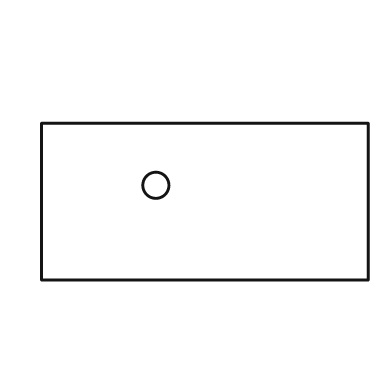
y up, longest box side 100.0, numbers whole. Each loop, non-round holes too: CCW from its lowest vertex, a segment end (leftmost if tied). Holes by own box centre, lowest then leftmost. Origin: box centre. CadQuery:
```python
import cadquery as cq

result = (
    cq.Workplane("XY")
    .moveTo(-50.0, -24.0)
    .lineTo(50.0, -24.0)
    .lineTo(50.0, 24.0)
    .lineTo(-50.0, 24.0)
    .close()
    .moveTo(-15.0, 5.0)
    .circle(4.0)
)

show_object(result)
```